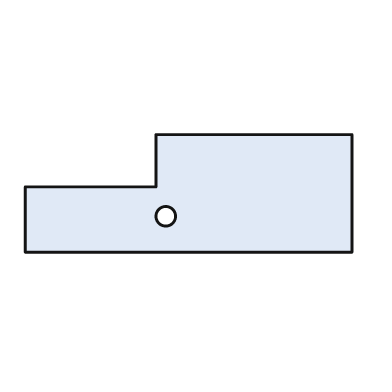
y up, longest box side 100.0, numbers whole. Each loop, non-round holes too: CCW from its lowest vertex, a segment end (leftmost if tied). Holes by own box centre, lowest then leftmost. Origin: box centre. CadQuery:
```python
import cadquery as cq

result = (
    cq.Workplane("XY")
    .moveTo(-50.0, -18.0)
    .lineTo(50.0, -18.0)
    .lineTo(50.0, 18.0)
    .lineTo(-10.0, 18.0)
    .lineTo(-10.0, 2.0)
    .lineTo(-50.0, 2.0)
    .close()
    .moveTo(-7.0, -7.0)
    .circle(3.0)
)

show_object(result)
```